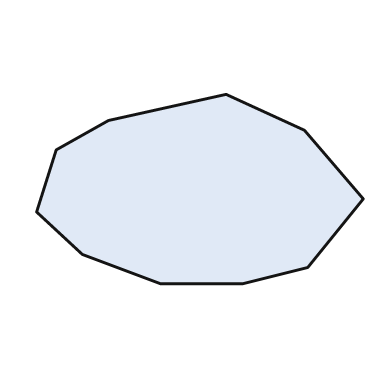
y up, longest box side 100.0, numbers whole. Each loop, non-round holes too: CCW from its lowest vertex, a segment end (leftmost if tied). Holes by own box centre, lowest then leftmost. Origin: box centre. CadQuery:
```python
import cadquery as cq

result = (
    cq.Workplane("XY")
    .moveTo(-12.0, -29.0)
    .lineTo(13.0, -29.0)
    .lineTo(33.0, -24.0)
    .lineTo(50.0, -3.0)
    .lineTo(32.0, 18.0)
    .lineTo(8.0, 29.0)
    .lineTo(-28.0, 21.0)
    .lineTo(-44.0, 12.0)
    .lineTo(-50.0, -7.0)
    .lineTo(-36.0, -20.0)
    .close()
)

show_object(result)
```